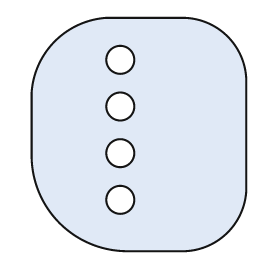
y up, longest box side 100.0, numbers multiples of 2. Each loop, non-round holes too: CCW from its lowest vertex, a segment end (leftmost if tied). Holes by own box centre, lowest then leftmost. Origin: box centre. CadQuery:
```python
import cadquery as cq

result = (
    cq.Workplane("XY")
    .moveTo(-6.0, -50.0)
    .lineTo(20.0, -50.0)
    .threePointArc((38.0, -42.0), (46.0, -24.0))
    .lineTo(46.0, 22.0)
    .threePointArc((38.0, 42.0), (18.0, 50.0))
    .lineTo(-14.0, 50.0)
    .threePointArc((-36.0, 40.0), (-46.0, 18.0))
    .lineTo(-46.0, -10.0)
    .threePointArc((-34.0, -38.0), (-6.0, -50.0))
    .close()
    .moveTo(-8.0, -28.0)
    .circle(6.0)
    .moveTo(-8.0, -8.0)
    .circle(6.0)
    .moveTo(-8.0, 12.0)
    .circle(6.0)
    .moveTo(-8.0, 32.0)
    .circle(6.0)
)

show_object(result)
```